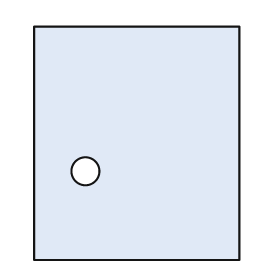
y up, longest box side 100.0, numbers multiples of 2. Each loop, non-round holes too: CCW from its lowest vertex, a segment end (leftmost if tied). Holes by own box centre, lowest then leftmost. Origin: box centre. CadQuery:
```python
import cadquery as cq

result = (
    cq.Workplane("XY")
    .moveTo(-44.0, -50.0)
    .lineTo(44.0, -50.0)
    .lineTo(44.0, 50.0)
    .lineTo(-44.0, 50.0)
    .close()
    .moveTo(-22.0, -12.0)
    .circle(6.0)
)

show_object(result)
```